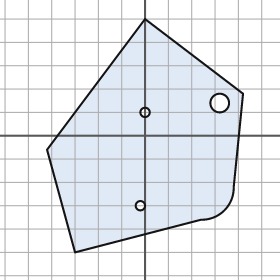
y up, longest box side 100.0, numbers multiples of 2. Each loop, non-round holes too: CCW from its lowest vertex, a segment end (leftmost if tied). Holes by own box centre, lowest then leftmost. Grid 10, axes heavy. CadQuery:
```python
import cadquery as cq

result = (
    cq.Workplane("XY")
    .moveTo(-30.0, -50.0)
    .lineTo(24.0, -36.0)
    .threePointArc((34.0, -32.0), (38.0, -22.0))
    .lineTo(42.0, 18.0)
    .lineTo(0.0, 50.0)
    .lineTo(-42.0, -6.0)
    .close()
    .moveTo(-2.0, -30.0)
    .circle(2.0)
    .moveTo(0.0, 10.0)
    .circle(2.0)
    .moveTo(32.0, 14.0)
    .circle(4.0)
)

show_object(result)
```